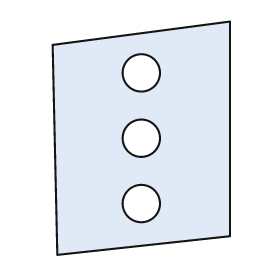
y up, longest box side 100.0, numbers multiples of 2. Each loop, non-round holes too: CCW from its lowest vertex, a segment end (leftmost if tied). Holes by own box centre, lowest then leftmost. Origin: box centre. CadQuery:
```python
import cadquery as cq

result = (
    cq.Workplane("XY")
    .moveTo(-36.0, -50.0)
    .lineTo(38.0, -42.0)
    .lineTo(38.0, 50.0)
    .lineTo(-38.0, 40.0)
    .close()
    .moveTo(0.0, -28.0)
    .circle(8.0)
    .moveTo(0.0, 0.0)
    .circle(8.0)
    .moveTo(0.0, 28.0)
    .circle(8.0)
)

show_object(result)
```